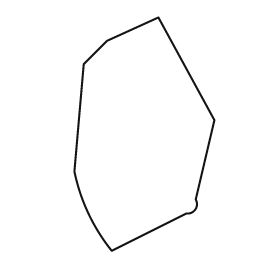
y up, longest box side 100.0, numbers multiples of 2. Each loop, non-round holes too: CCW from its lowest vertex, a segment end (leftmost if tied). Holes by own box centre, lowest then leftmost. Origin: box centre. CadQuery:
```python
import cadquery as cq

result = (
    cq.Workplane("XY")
    .moveTo(-14.0, -50.0)
    .lineTo(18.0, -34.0)
    .threePointArc((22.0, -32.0), (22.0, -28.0))
    .lineTo(30.0, 6.0)
    .lineTo(6.0, 50.0)
    .lineTo(-16.0, 40.0)
    .lineTo(-26.0, 30.0)
    .lineTo(-30.0, -16.0)
    .threePointArc((-24.0, -34.0), (-14.0, -50.0))
    .close()
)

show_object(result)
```